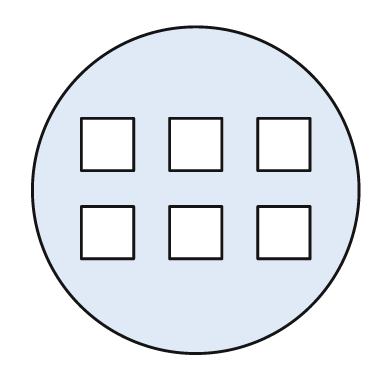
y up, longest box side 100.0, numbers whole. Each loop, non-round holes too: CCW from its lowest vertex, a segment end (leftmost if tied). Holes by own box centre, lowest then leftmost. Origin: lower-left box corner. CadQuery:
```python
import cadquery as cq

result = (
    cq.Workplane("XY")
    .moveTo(50.0, 50.0)
    .circle(50.0)
    .moveTo(15.0, 29.0)
    .lineTo(31.0, 29.0)
    .lineTo(31.0, 45.0)
    .lineTo(15.0, 45.0)
    .close()
    .moveTo(42.0, 29.0)
    .lineTo(58.0, 29.0)
    .lineTo(58.0, 45.0)
    .lineTo(42.0, 45.0)
    .close()
    .moveTo(69.0, 29.0)
    .lineTo(85.0, 29.0)
    .lineTo(85.0, 45.0)
    .lineTo(69.0, 45.0)
    .close()
    .moveTo(15.0, 56.0)
    .lineTo(31.0, 56.0)
    .lineTo(31.0, 72.0)
    .lineTo(15.0, 72.0)
    .close()
    .moveTo(42.0, 56.0)
    .lineTo(58.0, 56.0)
    .lineTo(58.0, 72.0)
    .lineTo(42.0, 72.0)
    .close()
    .moveTo(69.0, 56.0)
    .lineTo(85.0, 56.0)
    .lineTo(85.0, 72.0)
    .lineTo(69.0, 72.0)
    .close()
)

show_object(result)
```